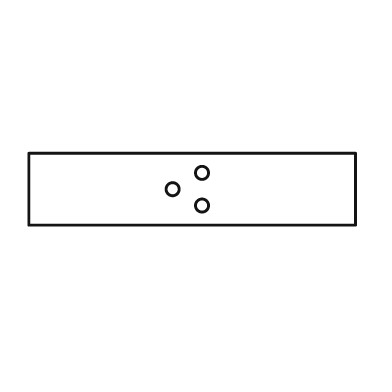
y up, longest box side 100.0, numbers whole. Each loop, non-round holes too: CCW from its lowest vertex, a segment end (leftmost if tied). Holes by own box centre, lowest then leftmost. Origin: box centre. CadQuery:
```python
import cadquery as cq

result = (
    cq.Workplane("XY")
    .moveTo(-50.0, -11.0)
    .lineTo(50.0, -11.0)
    .lineTo(50.0, 11.0)
    .lineTo(-50.0, 11.0)
    .close()
    .moveTo(3.0, -5.0)
    .circle(2.0)
    .moveTo(-6.0, 0.0)
    .circle(2.0)
    .moveTo(3.0, 5.0)
    .circle(2.0)
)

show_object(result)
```